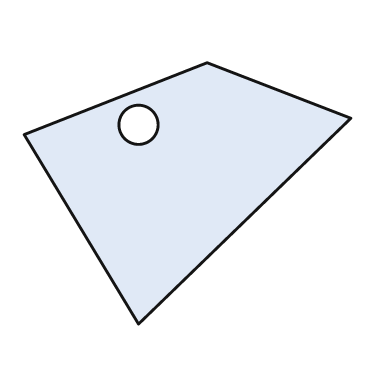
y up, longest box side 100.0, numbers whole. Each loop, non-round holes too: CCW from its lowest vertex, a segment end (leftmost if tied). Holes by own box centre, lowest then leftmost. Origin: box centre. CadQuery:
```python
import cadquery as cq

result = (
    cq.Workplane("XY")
    .moveTo(-15.0, -40.0)
    .lineTo(50.0, 23.0)
    .lineTo(6.0, 40.0)
    .lineTo(-50.0, 18.0)
    .close()
    .moveTo(-15.0, 21.0)
    .circle(6.0)
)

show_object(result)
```